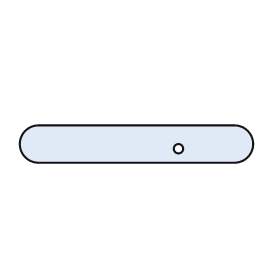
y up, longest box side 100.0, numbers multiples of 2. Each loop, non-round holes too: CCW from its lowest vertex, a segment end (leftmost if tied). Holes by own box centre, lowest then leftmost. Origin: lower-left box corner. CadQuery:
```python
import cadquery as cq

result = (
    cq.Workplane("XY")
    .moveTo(8.0, 0.0)
    .lineTo(92.0, 0.0)
    .threePointArc((100.0, 8.0), (92.0, 16.0))
    .lineTo(8.0, 16.0)
    .threePointArc((0.0, 8.0), (8.0, 0.0))
    .close()
    .moveTo(68.0, 6.0)
    .circle(2.0)
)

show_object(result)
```